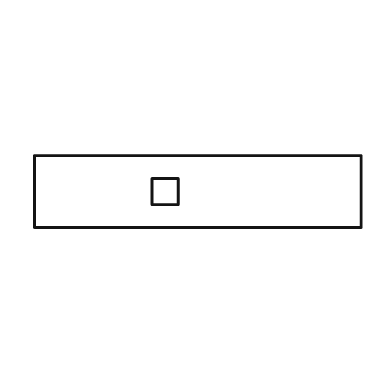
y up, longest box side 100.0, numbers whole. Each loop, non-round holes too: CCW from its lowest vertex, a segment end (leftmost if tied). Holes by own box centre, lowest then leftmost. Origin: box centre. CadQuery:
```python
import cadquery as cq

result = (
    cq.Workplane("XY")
    .moveTo(-50.0, -11.0)
    .lineTo(50.0, -11.0)
    .lineTo(50.0, 11.0)
    .lineTo(-50.0, 11.0)
    .close()
    .moveTo(-14.0, -4.0)
    .lineTo(-6.0, -4.0)
    .lineTo(-6.0, 4.0)
    .lineTo(-14.0, 4.0)
    .close()
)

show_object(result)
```